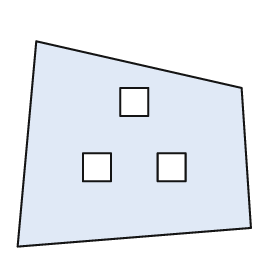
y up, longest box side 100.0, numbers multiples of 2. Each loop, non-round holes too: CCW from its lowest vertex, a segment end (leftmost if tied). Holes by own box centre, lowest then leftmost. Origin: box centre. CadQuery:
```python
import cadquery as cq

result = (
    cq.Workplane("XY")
    .moveTo(-50.0, -44.0)
    .lineTo(50.0, -36.0)
    .lineTo(46.0, 24.0)
    .lineTo(-42.0, 44.0)
    .close()
    .moveTo(-22.0, -16.0)
    .lineTo(-10.0, -16.0)
    .lineTo(-10.0, -4.0)
    .lineTo(-22.0, -4.0)
    .close()
    .moveTo(10.0, -16.0)
    .lineTo(22.0, -16.0)
    .lineTo(22.0, -4.0)
    .lineTo(10.0, -4.0)
    .close()
    .moveTo(-6.0, 12.0)
    .lineTo(6.0, 12.0)
    .lineTo(6.0, 24.0)
    .lineTo(-6.0, 24.0)
    .close()
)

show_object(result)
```